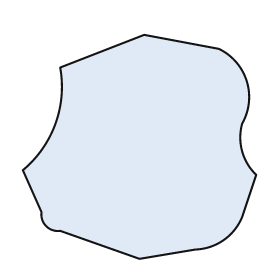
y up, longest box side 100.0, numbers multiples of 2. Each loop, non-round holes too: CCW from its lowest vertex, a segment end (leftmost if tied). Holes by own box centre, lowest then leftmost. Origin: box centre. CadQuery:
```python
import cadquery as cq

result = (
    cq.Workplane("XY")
    .moveTo(0.0, -48.0)
    .lineTo(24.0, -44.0)
    .threePointArc((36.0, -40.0), (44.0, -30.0))
    .lineTo(50.0, -12.0)
    .threePointArc((44.0, -2.0), (44.0, 10.0))
    .threePointArc((46.0, 28.0), (34.0, 42.0))
    .lineTo(2.0, 48.0)
    .lineTo(-34.0, 34.0)
    .threePointArc((-36.0, 10.0), (-50.0, -10.0))
    .lineTo(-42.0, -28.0)
    .threePointArc((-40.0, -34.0), (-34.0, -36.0))
    .close()
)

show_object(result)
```